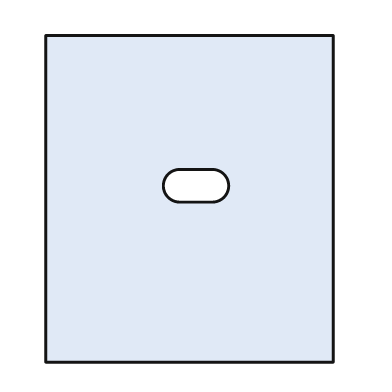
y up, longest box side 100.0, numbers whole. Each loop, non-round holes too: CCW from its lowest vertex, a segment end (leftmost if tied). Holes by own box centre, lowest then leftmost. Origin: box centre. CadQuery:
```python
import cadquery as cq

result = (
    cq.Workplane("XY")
    .moveTo(-44.0, -50.0)
    .lineTo(44.0, -50.0)
    .lineTo(44.0, 50.0)
    .lineTo(-44.0, 50.0)
    .close()
    .moveTo(-3.0, -1.0)
    .lineTo(7.0, -1.0)
    .threePointArc((12.0, 4.0), (7.0, 9.0))
    .lineTo(-3.0, 9.0)
    .threePointArc((-8.0, 4.0), (-3.0, -1.0))
    .close()
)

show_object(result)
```